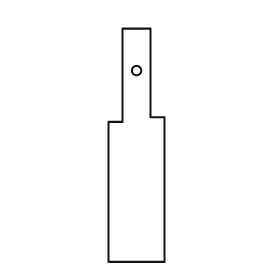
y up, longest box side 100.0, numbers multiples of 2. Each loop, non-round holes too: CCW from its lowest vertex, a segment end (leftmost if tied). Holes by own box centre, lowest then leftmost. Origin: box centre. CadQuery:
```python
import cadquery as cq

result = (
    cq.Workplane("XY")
    .moveTo(-12.0, -50.0)
    .lineTo(12.0, -50.0)
    .lineTo(12.0, 12.0)
    .lineTo(6.0, 12.0)
    .lineTo(6.0, 50.0)
    .lineTo(-6.0, 50.0)
    .lineTo(-6.0, 10.0)
    .lineTo(-12.0, 10.0)
    .close()
    .moveTo(0.0, 32.0)
    .circle(2.0)
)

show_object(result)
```